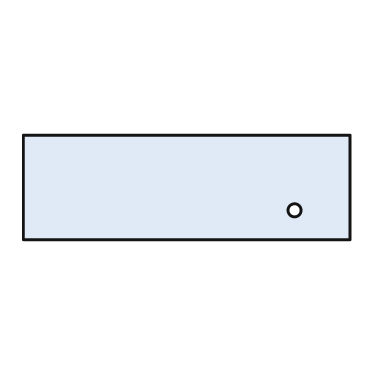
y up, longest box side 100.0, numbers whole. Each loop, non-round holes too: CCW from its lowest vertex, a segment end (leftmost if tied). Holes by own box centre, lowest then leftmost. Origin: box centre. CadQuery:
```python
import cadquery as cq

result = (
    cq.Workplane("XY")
    .moveTo(-50.0, -16.0)
    .lineTo(50.0, -16.0)
    .lineTo(50.0, 16.0)
    .lineTo(-50.0, 16.0)
    .close()
    .moveTo(33.0, -7.0)
    .circle(2.0)
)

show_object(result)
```